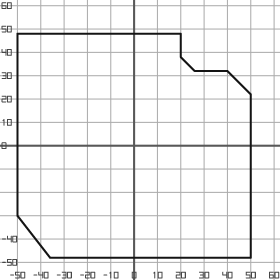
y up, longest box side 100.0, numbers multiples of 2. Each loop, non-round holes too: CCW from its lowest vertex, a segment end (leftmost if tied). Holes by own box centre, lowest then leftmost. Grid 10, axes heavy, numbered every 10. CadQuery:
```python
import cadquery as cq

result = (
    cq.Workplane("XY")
    .moveTo(-36.0, -48.0)
    .lineTo(50.0, -48.0)
    .lineTo(50.0, 22.0)
    .lineTo(40.0, 32.0)
    .lineTo(26.0, 32.0)
    .lineTo(20.0, 38.0)
    .lineTo(20.0, 48.0)
    .lineTo(-50.0, 48.0)
    .lineTo(-50.0, -30.0)
    .close()
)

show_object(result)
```